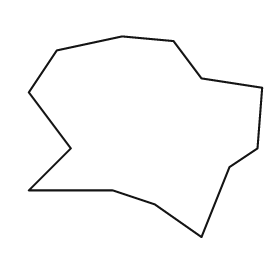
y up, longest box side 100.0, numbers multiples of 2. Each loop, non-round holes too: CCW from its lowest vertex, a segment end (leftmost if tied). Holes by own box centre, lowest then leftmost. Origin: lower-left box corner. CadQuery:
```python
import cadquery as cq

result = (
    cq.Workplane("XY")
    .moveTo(74.0, 0.0)
    .lineTo(86.0, 30.0)
    .lineTo(98.0, 38.0)
    .lineTo(100.0, 64.0)
    .lineTo(74.0, 68.0)
    .lineTo(62.0, 84.0)
    .lineTo(40.0, 86.0)
    .lineTo(12.0, 80.0)
    .lineTo(0.0, 62.0)
    .lineTo(18.0, 38.0)
    .lineTo(0.0, 20.0)
    .lineTo(36.0, 20.0)
    .lineTo(54.0, 14.0)
    .close()
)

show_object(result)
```